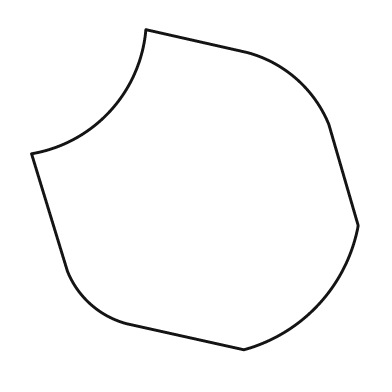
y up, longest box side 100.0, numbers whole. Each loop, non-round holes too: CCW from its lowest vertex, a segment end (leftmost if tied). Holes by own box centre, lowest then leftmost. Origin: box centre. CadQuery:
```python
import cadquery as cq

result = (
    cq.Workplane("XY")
    .moveTo(15.0, -49.0)
    .threePointArc((38.0, -35.0), (50.0, -11.0))
    .lineTo(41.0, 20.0)
    .threePointArc((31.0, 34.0), (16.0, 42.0))
    .lineTo(-15.0, 49.0)
    .threePointArc((-26.0, 24.0), (-50.0, 11.0))
    .lineTo(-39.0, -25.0)
    .threePointArc((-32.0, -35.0), (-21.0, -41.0))
    .close()
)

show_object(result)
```